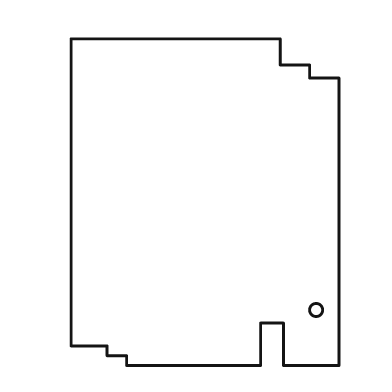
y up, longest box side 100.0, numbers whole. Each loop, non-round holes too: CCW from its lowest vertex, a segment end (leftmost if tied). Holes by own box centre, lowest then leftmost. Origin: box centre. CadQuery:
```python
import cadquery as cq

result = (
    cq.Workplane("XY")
    .moveTo(-24.0, -50.0)
    .lineTo(17.0, -50.0)
    .lineTo(17.0, -37.0)
    .lineTo(24.0, -37.0)
    .lineTo(24.0, -50.0)
    .lineTo(41.0, -50.0)
    .lineTo(41.0, 38.0)
    .lineTo(32.0, 38.0)
    .lineTo(32.0, 42.0)
    .lineTo(23.0, 42.0)
    .lineTo(23.0, 50.0)
    .lineTo(-41.0, 50.0)
    .lineTo(-41.0, -44.0)
    .lineTo(-30.0, -44.0)
    .lineTo(-30.0, -47.0)
    .lineTo(-24.0, -47.0)
    .close()
    .moveTo(34.0, -33.0)
    .circle(2.0)
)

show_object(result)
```